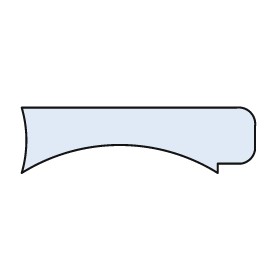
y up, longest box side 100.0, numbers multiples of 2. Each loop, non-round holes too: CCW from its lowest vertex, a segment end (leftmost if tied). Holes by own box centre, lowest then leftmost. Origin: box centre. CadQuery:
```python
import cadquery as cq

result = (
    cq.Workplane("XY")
    .moveTo(-50.0, -14.0)
    .threePointArc((-8.0, -2.0), (34.0, -14.0))
    .lineTo(34.0, -10.0)
    .lineTo(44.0, -10.0)
    .threePointArc((48.0, -8.0), (50.0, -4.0))
    .lineTo(50.0, 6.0)
    .threePointArc((48.0, 12.0), (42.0, 14.0))
    .lineTo(-50.0, 14.0)
    .threePointArc((-48.0, 0.0), (-50.0, -14.0))
    .close()
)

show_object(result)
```